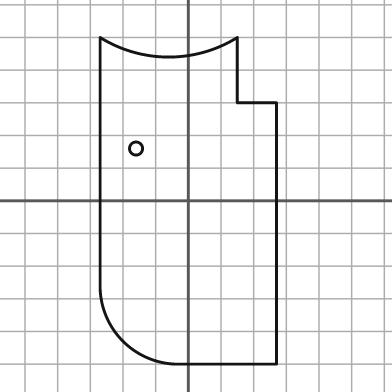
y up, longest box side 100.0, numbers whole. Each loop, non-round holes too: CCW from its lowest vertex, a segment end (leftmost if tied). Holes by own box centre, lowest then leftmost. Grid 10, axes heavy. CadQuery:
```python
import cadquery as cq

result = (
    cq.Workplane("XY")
    .moveTo(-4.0, -50.0)
    .lineTo(27.0, -50.0)
    .lineTo(27.0, 30.0)
    .lineTo(15.0, 30.0)
    .lineTo(15.0, 50.0)
    .threePointArc((-6.0, 44.0), (-27.0, 50.0))
    .lineTo(-27.0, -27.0)
    .threePointArc((-20.0, -43.0), (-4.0, -50.0))
    .close()
    .moveTo(-16.0, 16.0)
    .circle(2.0)
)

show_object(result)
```